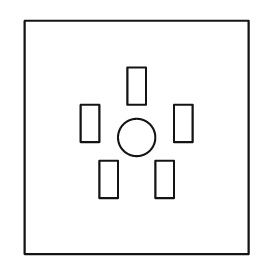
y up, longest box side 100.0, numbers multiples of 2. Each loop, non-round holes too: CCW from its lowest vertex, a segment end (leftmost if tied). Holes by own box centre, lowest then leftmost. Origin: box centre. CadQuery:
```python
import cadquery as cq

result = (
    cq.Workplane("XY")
    .moveTo(-48.0, -50.0)
    .lineTo(48.0, -50.0)
    .lineTo(48.0, 50.0)
    .lineTo(-48.0, 50.0)
    .close()
    .moveTo(-16.0, -26.0)
    .lineTo(-8.0, -26.0)
    .lineTo(-8.0, -10.0)
    .lineTo(-16.0, -10.0)
    .close()
    .moveTo(8.0, -26.0)
    .lineTo(16.0, -26.0)
    .lineTo(16.0, -10.0)
    .lineTo(8.0, -10.0)
    .close()
    .moveTo(0.0, 0.0)
    .circle(8.0)
    .moveTo(-24.0, -2.0)
    .lineTo(-16.0, -2.0)
    .lineTo(-16.0, 14.0)
    .lineTo(-24.0, 14.0)
    .close()
    .moveTo(16.0, -2.0)
    .lineTo(24.0, -2.0)
    .lineTo(24.0, 14.0)
    .lineTo(16.0, 14.0)
    .close()
    .moveTo(-4.0, 14.0)
    .lineTo(4.0, 14.0)
    .lineTo(4.0, 30.0)
    .lineTo(-4.0, 30.0)
    .close()
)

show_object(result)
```